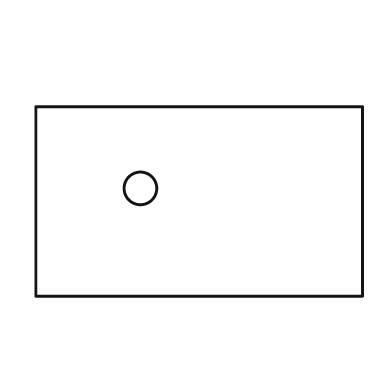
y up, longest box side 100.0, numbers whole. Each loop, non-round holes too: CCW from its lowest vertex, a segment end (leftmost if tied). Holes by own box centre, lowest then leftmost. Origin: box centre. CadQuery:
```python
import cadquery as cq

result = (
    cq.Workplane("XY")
    .moveTo(-50.0, -29.0)
    .lineTo(50.0, -29.0)
    .lineTo(50.0, 29.0)
    .lineTo(-50.0, 29.0)
    .close()
    .moveTo(-18.0, 4.0)
    .circle(5.0)
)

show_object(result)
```